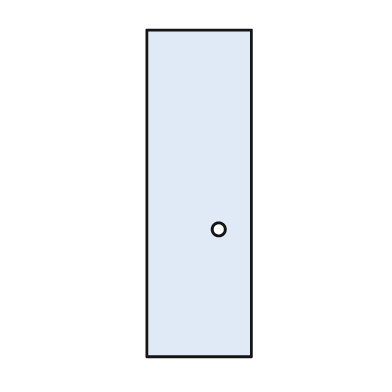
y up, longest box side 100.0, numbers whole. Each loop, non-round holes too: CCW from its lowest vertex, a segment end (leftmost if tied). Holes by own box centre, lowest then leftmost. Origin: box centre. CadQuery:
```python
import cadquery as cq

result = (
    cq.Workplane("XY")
    .moveTo(-16.0, -50.0)
    .lineTo(16.0, -50.0)
    .lineTo(16.0, 50.0)
    .lineTo(-16.0, 50.0)
    .close()
    .moveTo(6.0, -11.0)
    .circle(2.0)
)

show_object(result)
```